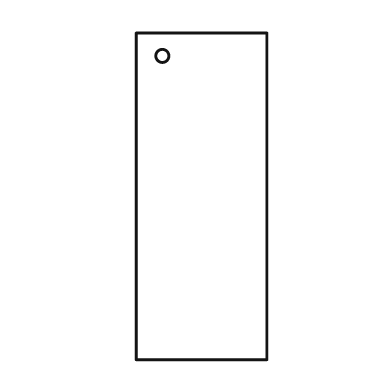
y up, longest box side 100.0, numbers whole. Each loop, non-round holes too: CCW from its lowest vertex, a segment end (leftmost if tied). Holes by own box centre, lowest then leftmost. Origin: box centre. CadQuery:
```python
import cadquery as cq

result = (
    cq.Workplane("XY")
    .moveTo(-20.0, -50.0)
    .lineTo(20.0, -50.0)
    .lineTo(20.0, 50.0)
    .lineTo(-20.0, 50.0)
    .close()
    .moveTo(-12.0, 43.0)
    .circle(2.0)
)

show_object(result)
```